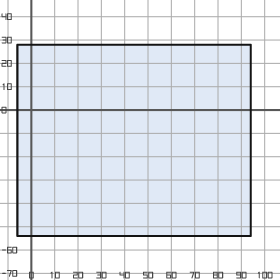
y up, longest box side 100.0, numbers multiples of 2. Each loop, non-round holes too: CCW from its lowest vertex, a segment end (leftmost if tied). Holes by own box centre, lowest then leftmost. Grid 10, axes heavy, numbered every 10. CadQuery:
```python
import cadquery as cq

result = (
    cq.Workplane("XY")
    .moveTo(-6.0, -54.0)
    .lineTo(94.0, -54.0)
    .lineTo(94.0, 28.0)
    .lineTo(-6.0, 28.0)
    .close()
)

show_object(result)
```